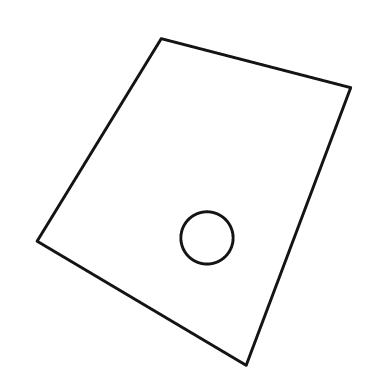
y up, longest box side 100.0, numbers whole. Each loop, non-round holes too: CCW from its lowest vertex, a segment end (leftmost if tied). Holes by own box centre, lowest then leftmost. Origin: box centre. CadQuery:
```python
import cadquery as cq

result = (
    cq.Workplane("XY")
    .moveTo(16.0, -50.0)
    .lineTo(48.0, 35.0)
    .lineTo(-10.0, 50.0)
    .lineTo(-48.0, -12.0)
    .close()
    .moveTo(4.0, -11.0)
    .circle(8.0)
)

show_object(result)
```